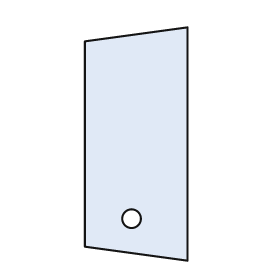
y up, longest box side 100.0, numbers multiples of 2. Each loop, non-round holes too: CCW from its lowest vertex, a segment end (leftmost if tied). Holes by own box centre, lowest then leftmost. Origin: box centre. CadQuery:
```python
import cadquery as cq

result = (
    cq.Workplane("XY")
    .moveTo(22.0, -50.0)
    .lineTo(22.0, 50.0)
    .lineTo(-22.0, 44.0)
    .lineTo(-22.0, -44.0)
    .close()
    .moveTo(-2.0, -32.0)
    .circle(4.0)
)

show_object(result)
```